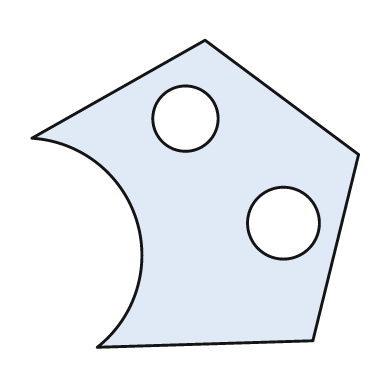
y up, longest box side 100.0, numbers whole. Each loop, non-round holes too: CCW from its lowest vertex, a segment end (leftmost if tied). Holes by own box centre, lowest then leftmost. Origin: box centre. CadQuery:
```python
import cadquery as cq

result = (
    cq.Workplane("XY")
    .moveTo(-30.0, -47.0)
    .lineTo(36.0, -45.0)
    .lineTo(50.0, 12.0)
    .lineTo(3.0, 47.0)
    .lineTo(-50.0, 17.0)
    .threePointArc((-18.0, -8.0), (-30.0, -47.0))
    .close()
    .moveTo(27.0, -9.0)
    .circle(11.0)
    .moveTo(-3.0, 23.0)
    .circle(10.0)
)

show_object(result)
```